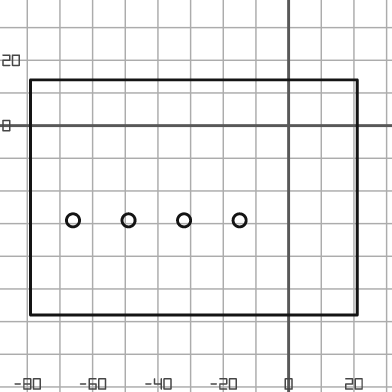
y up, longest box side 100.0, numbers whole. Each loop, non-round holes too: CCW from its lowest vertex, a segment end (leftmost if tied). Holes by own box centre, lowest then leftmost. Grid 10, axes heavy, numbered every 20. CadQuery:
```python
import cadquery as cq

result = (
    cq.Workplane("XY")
    .moveTo(-79.0, -58.0)
    .lineTo(21.0, -58.0)
    .lineTo(21.0, 14.0)
    .lineTo(-79.0, 14.0)
    .close()
    .moveTo(-66.0, -29.0)
    .circle(2.0)
    .moveTo(-49.0, -29.0)
    .circle(2.0)
    .moveTo(-32.0, -29.0)
    .circle(2.0)
    .moveTo(-15.0, -29.0)
    .circle(2.0)
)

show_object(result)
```